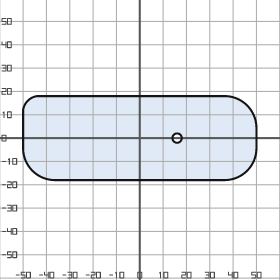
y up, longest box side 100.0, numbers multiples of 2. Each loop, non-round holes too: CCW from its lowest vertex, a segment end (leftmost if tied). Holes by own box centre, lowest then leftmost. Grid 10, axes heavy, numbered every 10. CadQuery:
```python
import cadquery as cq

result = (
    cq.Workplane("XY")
    .moveTo(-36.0, -18.0)
    .lineTo(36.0, -18.0)
    .threePointArc((46.0, -14.0), (50.0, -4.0))
    .lineTo(50.0, 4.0)
    .threePointArc((46.0, 14.0), (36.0, 18.0))
    .lineTo(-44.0, 18.0)
    .threePointArc((-48.0, 16.0), (-50.0, 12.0))
    .lineTo(-50.0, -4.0)
    .threePointArc((-46.0, -14.0), (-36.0, -18.0))
    .close()
    .moveTo(16.0, 0.0)
    .circle(2.0)
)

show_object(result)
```